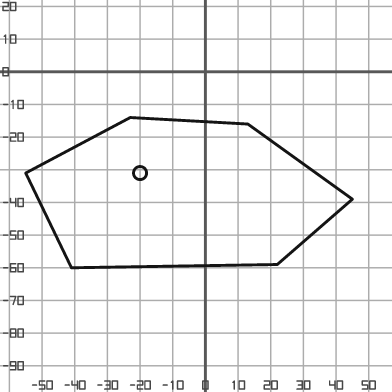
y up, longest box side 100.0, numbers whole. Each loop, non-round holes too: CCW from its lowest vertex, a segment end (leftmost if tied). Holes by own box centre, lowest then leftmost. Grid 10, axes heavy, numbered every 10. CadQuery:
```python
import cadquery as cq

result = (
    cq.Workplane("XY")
    .moveTo(-41.0, -60.0)
    .lineTo(22.0, -59.0)
    .lineTo(45.0, -39.0)
    .lineTo(13.0, -16.0)
    .lineTo(-23.0, -14.0)
    .lineTo(-55.0, -31.0)
    .close()
    .moveTo(-20.0, -31.0)
    .circle(2.0)
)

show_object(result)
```